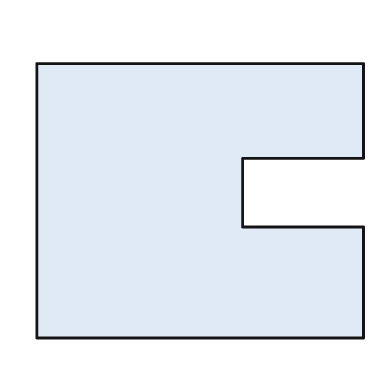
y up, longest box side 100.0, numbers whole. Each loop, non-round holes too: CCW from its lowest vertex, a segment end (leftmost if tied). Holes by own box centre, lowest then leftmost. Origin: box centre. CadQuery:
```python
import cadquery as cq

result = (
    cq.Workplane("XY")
    .moveTo(-50.0, -42.0)
    .lineTo(50.0, -42.0)
    .lineTo(50.0, -8.0)
    .lineTo(13.0, -8.0)
    .lineTo(13.0, 13.0)
    .lineTo(50.0, 13.0)
    .lineTo(50.0, 42.0)
    .lineTo(-50.0, 42.0)
    .close()
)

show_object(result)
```